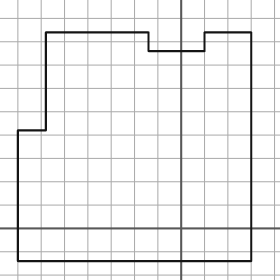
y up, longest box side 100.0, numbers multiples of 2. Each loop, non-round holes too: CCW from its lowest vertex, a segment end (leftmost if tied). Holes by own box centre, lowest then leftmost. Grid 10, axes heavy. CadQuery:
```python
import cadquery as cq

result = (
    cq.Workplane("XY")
    .moveTo(-70.0, -14.0)
    .lineTo(30.0, -14.0)
    .lineTo(30.0, 84.0)
    .lineTo(10.0, 84.0)
    .lineTo(10.0, 76.0)
    .lineTo(-14.0, 76.0)
    .lineTo(-14.0, 84.0)
    .lineTo(-58.0, 84.0)
    .lineTo(-58.0, 42.0)
    .lineTo(-70.0, 42.0)
    .close()
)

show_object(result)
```